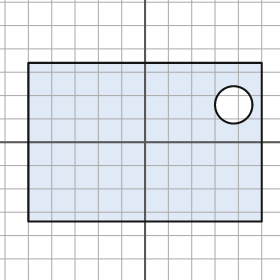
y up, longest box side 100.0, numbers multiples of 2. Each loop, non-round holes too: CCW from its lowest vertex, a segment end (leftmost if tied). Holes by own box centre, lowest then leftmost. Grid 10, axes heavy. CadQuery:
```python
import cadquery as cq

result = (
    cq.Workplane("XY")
    .moveTo(-50.0, -34.0)
    .lineTo(50.0, -34.0)
    .lineTo(50.0, 34.0)
    .lineTo(-50.0, 34.0)
    .close()
    .moveTo(38.0, 16.0)
    .circle(8.0)
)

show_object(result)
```